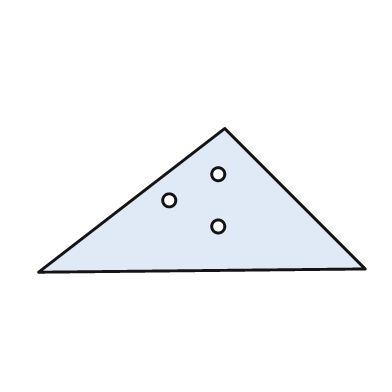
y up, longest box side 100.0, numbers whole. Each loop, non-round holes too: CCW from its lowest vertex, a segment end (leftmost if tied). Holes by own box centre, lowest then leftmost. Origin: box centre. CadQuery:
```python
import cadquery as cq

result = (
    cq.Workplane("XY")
    .moveTo(-50.0, -22.0)
    .lineTo(50.0, -21.0)
    .lineTo(7.0, 22.0)
    .close()
    .moveTo(5.0, -8.0)
    .circle(2.0)
    .moveTo(-10.0, 0.0)
    .circle(2.0)
    .moveTo(5.0, 8.0)
    .circle(2.0)
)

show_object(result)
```